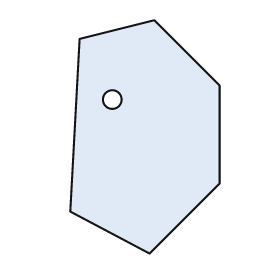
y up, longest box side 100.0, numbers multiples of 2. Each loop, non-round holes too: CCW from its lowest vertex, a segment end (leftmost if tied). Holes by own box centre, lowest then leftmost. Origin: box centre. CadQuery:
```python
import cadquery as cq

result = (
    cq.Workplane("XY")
    .moveTo(2.0, -50.0)
    .lineTo(32.0, -20.0)
    .lineTo(32.0, 22.0)
    .lineTo(4.0, 50.0)
    .lineTo(-28.0, 42.0)
    .lineTo(-32.0, -32.0)
    .close()
    .moveTo(-14.0, 16.0)
    .circle(4.0)
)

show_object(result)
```